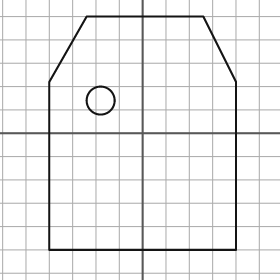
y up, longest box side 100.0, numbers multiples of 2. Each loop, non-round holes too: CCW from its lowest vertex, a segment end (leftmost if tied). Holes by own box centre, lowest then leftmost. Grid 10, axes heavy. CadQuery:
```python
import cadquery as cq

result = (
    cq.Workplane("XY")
    .moveTo(-40.0, -50.0)
    .lineTo(40.0, -50.0)
    .lineTo(40.0, 22.0)
    .lineTo(26.0, 50.0)
    .lineTo(-24.0, 50.0)
    .lineTo(-40.0, 22.0)
    .close()
    .moveTo(-18.0, 14.0)
    .circle(6.0)
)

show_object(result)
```